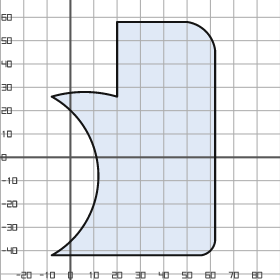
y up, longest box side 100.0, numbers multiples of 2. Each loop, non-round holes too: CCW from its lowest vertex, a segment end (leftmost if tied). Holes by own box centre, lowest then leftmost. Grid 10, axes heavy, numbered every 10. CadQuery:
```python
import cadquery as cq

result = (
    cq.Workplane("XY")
    .moveTo(-8.0, -42.0)
    .lineTo(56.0, -42.0)
    .threePointArc((60.0, -40.0), (62.0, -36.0))
    .lineTo(62.0, 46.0)
    .threePointArc((58.0, 54.0), (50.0, 58.0))
    .lineTo(20.0, 58.0)
    .lineTo(20.0, 26.0)
    .threePointArc((6.0, 28.0), (-8.0, 26.0))
    .threePointArc((12.0, -8.0), (-8.0, -42.0))
    .close()
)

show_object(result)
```